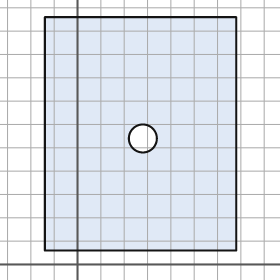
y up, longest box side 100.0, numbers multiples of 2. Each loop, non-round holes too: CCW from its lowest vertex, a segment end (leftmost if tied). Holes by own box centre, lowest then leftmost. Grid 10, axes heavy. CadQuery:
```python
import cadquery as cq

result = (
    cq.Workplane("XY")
    .moveTo(-14.0, 6.0)
    .lineTo(68.0, 6.0)
    .lineTo(68.0, 106.0)
    .lineTo(-14.0, 106.0)
    .close()
    .moveTo(28.0, 54.0)
    .circle(6.0)
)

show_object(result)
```